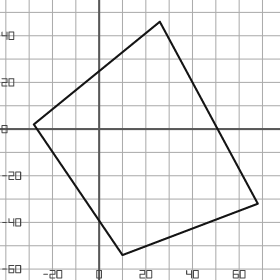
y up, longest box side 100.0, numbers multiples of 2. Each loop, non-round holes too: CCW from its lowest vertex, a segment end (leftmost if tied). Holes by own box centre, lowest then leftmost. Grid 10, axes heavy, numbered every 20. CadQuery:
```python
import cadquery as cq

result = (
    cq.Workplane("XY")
    .moveTo(10.0, -54.0)
    .lineTo(68.0, -32.0)
    .lineTo(26.0, 46.0)
    .lineTo(-28.0, 2.0)
    .close()
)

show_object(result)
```